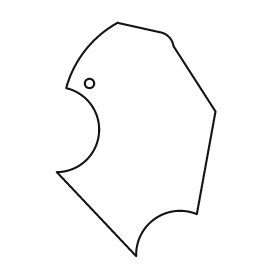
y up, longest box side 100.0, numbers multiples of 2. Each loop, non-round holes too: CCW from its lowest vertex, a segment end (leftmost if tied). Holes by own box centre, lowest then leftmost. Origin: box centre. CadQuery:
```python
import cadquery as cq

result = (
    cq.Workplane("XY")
    .moveTo(0.0, -50.0)
    .threePointArc((8.0, -34.0), (26.0, -32.0))
    .lineTo(34.0, 12.0)
    .lineTo(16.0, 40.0)
    .threePointArc((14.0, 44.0), (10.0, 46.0))
    .lineTo(-8.0, 50.0)
    .threePointArc((-22.0, 38.0), (-30.0, 22.0))
    .threePointArc((-16.0, 2.0), (-34.0, -14.0))
    .close()
    .moveTo(-20.0, 24.0)
    .circle(2.0)
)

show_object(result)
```